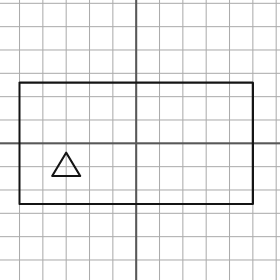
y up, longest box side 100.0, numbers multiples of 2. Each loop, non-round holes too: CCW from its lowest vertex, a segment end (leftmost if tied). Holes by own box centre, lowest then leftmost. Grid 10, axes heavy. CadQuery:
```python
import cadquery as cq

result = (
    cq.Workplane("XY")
    .moveTo(-50.0, -26.0)
    .lineTo(50.0, -26.0)
    .lineTo(50.0, 26.0)
    .lineTo(-50.0, 26.0)
    .close()
    .moveTo(-36.0, -14.0)
    .lineTo(-24.0, -14.0)
    .lineTo(-30.0, -4.0)
    .close()
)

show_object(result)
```